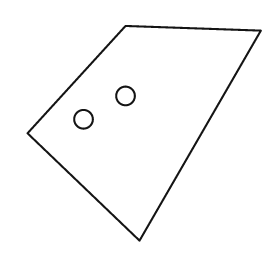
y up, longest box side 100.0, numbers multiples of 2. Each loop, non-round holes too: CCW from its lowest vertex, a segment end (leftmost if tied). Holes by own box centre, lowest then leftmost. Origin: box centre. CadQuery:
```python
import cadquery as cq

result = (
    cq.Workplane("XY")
    .moveTo(-2.0, -46.0)
    .lineTo(50.0, 44.0)
    .lineTo(-8.0, 46.0)
    .lineTo(-50.0, 0.0)
    .close()
    .moveTo(-26.0, 6.0)
    .circle(4.0)
    .moveTo(-8.0, 16.0)
    .circle(4.0)
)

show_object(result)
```